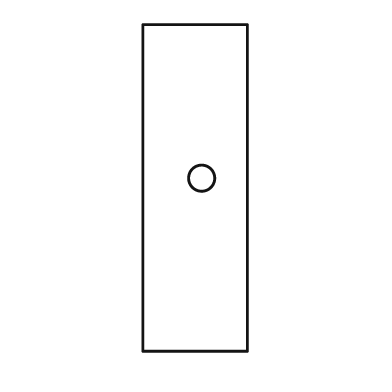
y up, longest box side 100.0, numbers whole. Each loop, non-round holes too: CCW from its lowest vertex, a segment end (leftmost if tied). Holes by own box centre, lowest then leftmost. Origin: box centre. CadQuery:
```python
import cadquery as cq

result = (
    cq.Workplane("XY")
    .moveTo(-16.0, -50.0)
    .lineTo(16.0, -50.0)
    .lineTo(16.0, 50.0)
    .lineTo(-16.0, 50.0)
    .close()
    .moveTo(2.0, 3.0)
    .circle(4.0)
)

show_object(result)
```